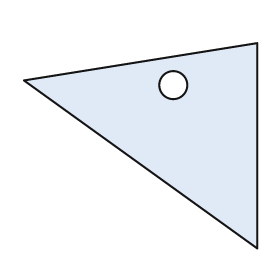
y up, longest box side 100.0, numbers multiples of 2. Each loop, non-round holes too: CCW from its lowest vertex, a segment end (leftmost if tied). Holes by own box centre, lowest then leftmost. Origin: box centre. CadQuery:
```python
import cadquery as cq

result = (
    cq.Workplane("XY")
    .moveTo(50.0, -44.0)
    .lineTo(50.0, 44.0)
    .lineTo(-50.0, 28.0)
    .close()
    .moveTo(14.0, 26.0)
    .circle(6.0)
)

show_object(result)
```